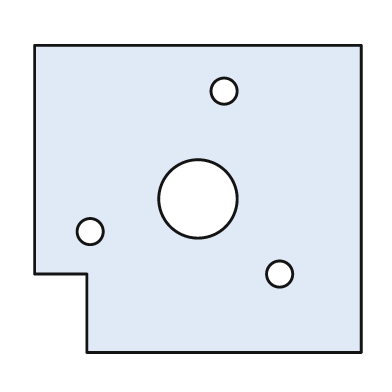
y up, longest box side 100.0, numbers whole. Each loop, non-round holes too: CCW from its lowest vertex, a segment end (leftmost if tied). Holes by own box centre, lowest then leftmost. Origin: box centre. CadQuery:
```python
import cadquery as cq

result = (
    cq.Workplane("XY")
    .moveTo(-34.0, -47.0)
    .lineTo(50.0, -47.0)
    .lineTo(50.0, 47.0)
    .lineTo(-50.0, 47.0)
    .lineTo(-50.0, -23.0)
    .lineTo(-34.0, -23.0)
    .close()
    .moveTo(25.0, -23.0)
    .circle(4.0)
    .moveTo(-33.0, -10.0)
    .circle(4.0)
    .moveTo(0.0, 0.0)
    .circle(12.0)
    .moveTo(8.0, 33.0)
    .circle(4.0)
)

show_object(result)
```